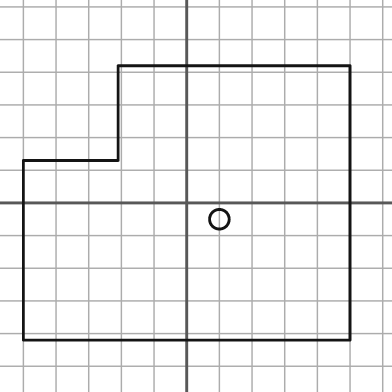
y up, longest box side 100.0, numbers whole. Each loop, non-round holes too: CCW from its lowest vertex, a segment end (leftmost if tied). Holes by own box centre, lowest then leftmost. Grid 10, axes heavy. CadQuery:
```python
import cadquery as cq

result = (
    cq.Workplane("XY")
    .moveTo(-50.0, -42.0)
    .lineTo(50.0, -42.0)
    .lineTo(50.0, 42.0)
    .lineTo(-21.0, 42.0)
    .lineTo(-21.0, 13.0)
    .lineTo(-50.0, 13.0)
    .close()
    .moveTo(10.0, -5.0)
    .circle(3.0)
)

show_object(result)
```